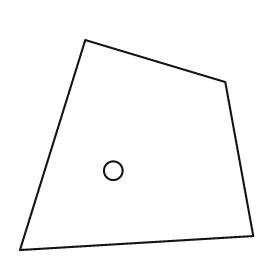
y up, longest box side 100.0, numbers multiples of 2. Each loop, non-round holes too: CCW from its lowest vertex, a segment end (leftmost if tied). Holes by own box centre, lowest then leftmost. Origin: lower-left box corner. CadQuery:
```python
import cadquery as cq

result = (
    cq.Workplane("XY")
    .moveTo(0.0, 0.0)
    .lineTo(100.0, 6.0)
    .lineTo(88.0, 72.0)
    .lineTo(28.0, 90.0)
    .close()
    .moveTo(40.0, 34.0)
    .circle(4.0)
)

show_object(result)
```